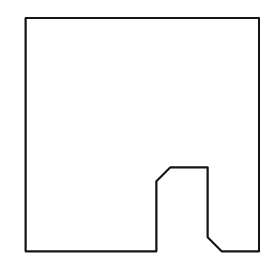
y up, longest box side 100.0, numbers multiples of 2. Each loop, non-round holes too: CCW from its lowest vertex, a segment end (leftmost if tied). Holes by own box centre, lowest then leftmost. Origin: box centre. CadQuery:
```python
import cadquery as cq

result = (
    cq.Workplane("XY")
    .moveTo(-50.0, -50.0)
    .lineTo(6.0, -50.0)
    .lineTo(6.0, -20.0)
    .lineTo(12.0, -14.0)
    .lineTo(28.0, -14.0)
    .lineTo(28.0, -44.0)
    .lineTo(34.0, -50.0)
    .lineTo(50.0, -50.0)
    .lineTo(50.0, 50.0)
    .lineTo(-50.0, 50.0)
    .close()
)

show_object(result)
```